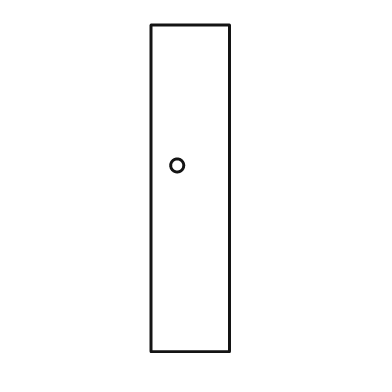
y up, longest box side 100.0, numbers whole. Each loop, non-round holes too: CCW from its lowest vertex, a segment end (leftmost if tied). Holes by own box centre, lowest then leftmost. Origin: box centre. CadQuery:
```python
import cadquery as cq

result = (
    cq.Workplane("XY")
    .moveTo(-12.0, -50.0)
    .lineTo(12.0, -50.0)
    .lineTo(12.0, 50.0)
    .lineTo(-12.0, 50.0)
    .close()
    .moveTo(-4.0, 7.0)
    .circle(2.0)
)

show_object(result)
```